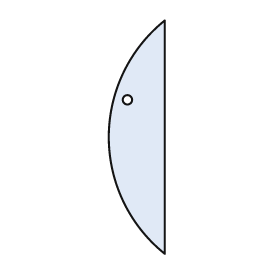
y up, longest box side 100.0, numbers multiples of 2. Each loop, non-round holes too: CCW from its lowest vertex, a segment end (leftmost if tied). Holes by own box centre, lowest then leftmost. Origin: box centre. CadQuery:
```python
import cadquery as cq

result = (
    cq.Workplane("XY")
    .moveTo(12.0, -50.0)
    .lineTo(12.0, 50.0)
    .threePointArc((-12.0, 0.0), (12.0, -50.0))
    .close()
    .moveTo(-4.0, 16.0)
    .circle(2.0)
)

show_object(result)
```